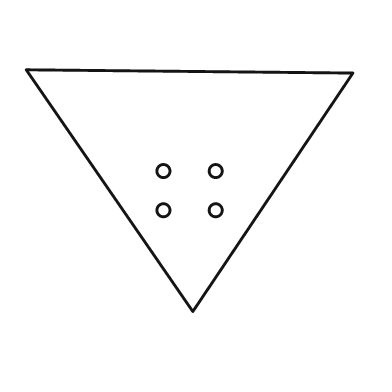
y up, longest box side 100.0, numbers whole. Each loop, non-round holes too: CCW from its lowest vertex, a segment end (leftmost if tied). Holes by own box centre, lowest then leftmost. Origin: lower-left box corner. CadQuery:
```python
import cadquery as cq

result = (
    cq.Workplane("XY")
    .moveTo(51.0, 0.0)
    .lineTo(100.0, 73.0)
    .lineTo(0.0, 74.0)
    .close()
    .moveTo(42.0, 31.0)
    .circle(2.0)
    .moveTo(58.0, 31.0)
    .circle(2.0)
    .moveTo(42.0, 43.0)
    .circle(2.0)
    .moveTo(58.0, 43.0)
    .circle(2.0)
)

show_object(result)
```